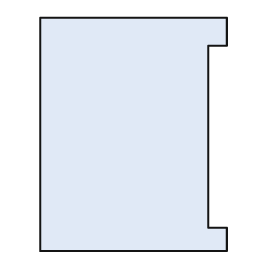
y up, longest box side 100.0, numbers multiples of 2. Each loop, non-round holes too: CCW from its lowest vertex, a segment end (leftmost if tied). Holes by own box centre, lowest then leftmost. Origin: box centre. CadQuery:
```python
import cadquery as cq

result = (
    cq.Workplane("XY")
    .moveTo(-40.0, -50.0)
    .lineTo(40.0, -50.0)
    .lineTo(40.0, -40.0)
    .lineTo(32.0, -40.0)
    .lineTo(32.0, 38.0)
    .lineTo(40.0, 38.0)
    .lineTo(40.0, 50.0)
    .lineTo(-40.0, 50.0)
    .close()
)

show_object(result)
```